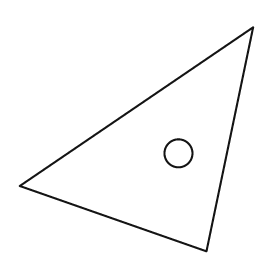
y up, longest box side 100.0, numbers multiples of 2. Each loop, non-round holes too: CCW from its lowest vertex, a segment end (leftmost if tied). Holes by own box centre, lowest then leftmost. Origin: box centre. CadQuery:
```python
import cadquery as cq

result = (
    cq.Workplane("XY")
    .moveTo(30.0, -48.0)
    .lineTo(50.0, 48.0)
    .lineTo(-50.0, -20.0)
    .close()
    .moveTo(18.0, -6.0)
    .circle(6.0)
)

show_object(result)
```